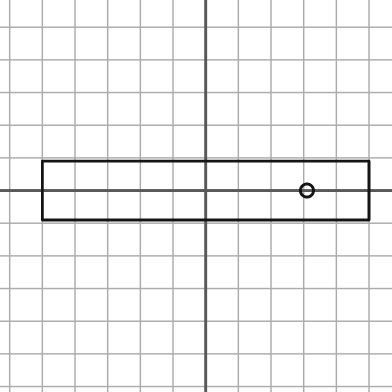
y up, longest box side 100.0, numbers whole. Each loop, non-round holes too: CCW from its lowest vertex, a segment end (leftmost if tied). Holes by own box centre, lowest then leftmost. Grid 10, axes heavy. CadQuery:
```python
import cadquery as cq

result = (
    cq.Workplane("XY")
    .moveTo(-50.0, -9.0)
    .lineTo(50.0, -9.0)
    .lineTo(50.0, 9.0)
    .lineTo(-50.0, 9.0)
    .close()
    .moveTo(31.0, 0.0)
    .circle(2.0)
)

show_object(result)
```